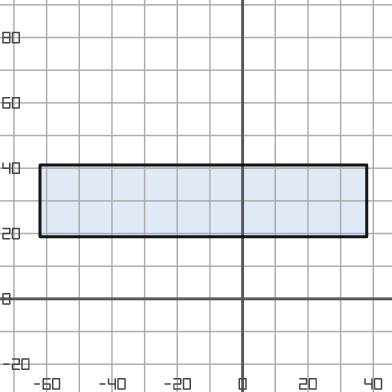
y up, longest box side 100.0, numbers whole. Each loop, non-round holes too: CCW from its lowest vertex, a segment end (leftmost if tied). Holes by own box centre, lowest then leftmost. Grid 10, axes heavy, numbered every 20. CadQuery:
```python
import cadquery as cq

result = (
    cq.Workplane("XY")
    .moveTo(-62.0, 19.0)
    .lineTo(38.0, 19.0)
    .lineTo(38.0, 41.0)
    .lineTo(-62.0, 41.0)
    .close()
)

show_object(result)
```